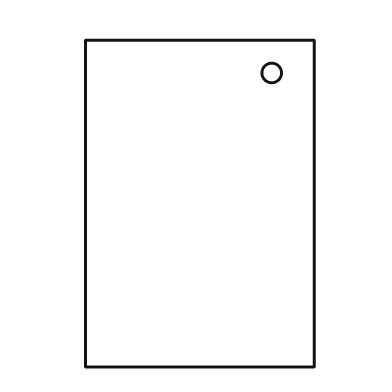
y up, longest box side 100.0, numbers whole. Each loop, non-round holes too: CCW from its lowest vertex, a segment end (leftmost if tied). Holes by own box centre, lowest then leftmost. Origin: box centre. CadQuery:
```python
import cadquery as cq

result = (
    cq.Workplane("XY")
    .moveTo(-35.0, -50.0)
    .lineTo(35.0, -50.0)
    .lineTo(35.0, 50.0)
    .lineTo(-35.0, 50.0)
    .close()
    .moveTo(22.0, 40.0)
    .circle(3.0)
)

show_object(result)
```